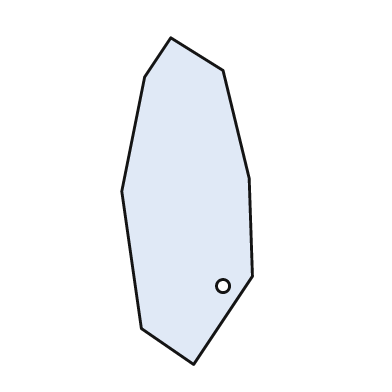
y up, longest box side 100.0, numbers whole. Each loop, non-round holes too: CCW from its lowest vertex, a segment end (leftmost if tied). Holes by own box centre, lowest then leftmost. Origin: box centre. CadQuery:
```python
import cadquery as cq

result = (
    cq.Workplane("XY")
    .moveTo(2.0, -50.0)
    .lineTo(20.0, -23.0)
    .lineTo(19.0, 7.0)
    .lineTo(11.0, 40.0)
    .lineTo(-5.0, 50.0)
    .lineTo(-13.0, 38.0)
    .lineTo(-20.0, 3.0)
    .lineTo(-14.0, -39.0)
    .close()
    .moveTo(11.0, -26.0)
    .circle(2.0)
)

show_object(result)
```